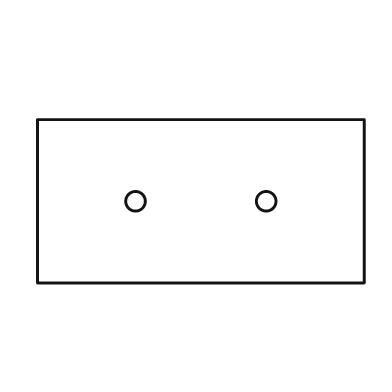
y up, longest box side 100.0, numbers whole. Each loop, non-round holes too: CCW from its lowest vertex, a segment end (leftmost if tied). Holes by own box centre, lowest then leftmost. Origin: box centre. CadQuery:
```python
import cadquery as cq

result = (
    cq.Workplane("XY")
    .moveTo(-50.0, -25.0)
    .lineTo(50.0, -25.0)
    .lineTo(50.0, 25.0)
    .lineTo(-50.0, 25.0)
    .close()
    .moveTo(-20.0, 0.0)
    .circle(3.0)
    .moveTo(20.0, 0.0)
    .circle(3.0)
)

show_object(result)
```